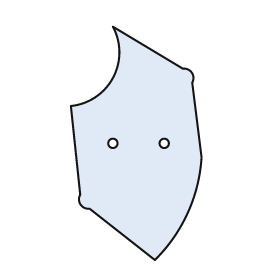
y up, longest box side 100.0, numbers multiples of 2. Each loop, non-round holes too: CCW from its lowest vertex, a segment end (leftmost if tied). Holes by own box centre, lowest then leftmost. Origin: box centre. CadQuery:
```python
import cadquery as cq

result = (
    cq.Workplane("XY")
    .moveTo(8.0, -50.0)
    .threePointArc((22.0, -30.0), (28.0, -6.0))
    .lineTo(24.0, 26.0)
    .threePointArc((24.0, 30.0), (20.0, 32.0))
    .lineTo(-10.0, 50.0)
    .threePointArc((-10.0, 28.0), (-28.0, 16.0))
    .lineTo(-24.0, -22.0)
    .threePointArc((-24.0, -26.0), (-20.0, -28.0))
    .close()
    .moveTo(-10.0, 0.0)
    .circle(2.0)
    .moveTo(12.0, 0.0)
    .circle(2.0)
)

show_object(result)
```